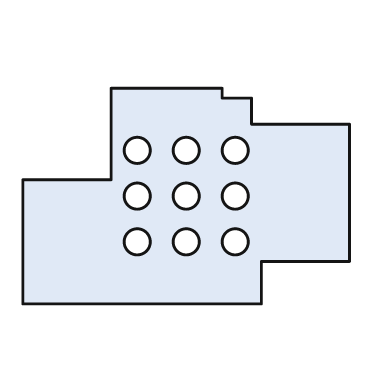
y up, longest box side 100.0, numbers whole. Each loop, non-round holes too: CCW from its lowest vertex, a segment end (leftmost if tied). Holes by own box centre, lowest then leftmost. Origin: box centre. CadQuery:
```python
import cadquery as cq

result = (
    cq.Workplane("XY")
    .moveTo(-50.0, -33.0)
    .lineTo(23.0, -33.0)
    .lineTo(23.0, -20.0)
    .lineTo(50.0, -20.0)
    .lineTo(50.0, 22.0)
    .lineTo(20.0, 22.0)
    .lineTo(20.0, 30.0)
    .lineTo(11.0, 30.0)
    .lineTo(11.0, 33.0)
    .lineTo(-23.0, 33.0)
    .lineTo(-23.0, 5.0)
    .lineTo(-50.0, 5.0)
    .close()
    .moveTo(-15.0, -14.0)
    .circle(4.0)
    .moveTo(0.0, -14.0)
    .circle(4.0)
    .moveTo(15.0, -14.0)
    .circle(4.0)
    .moveTo(-15.0, 0.0)
    .circle(4.0)
    .moveTo(0.0, 0.0)
    .circle(4.0)
    .moveTo(15.0, 0.0)
    .circle(4.0)
    .moveTo(-15.0, 14.0)
    .circle(4.0)
    .moveTo(0.0, 14.0)
    .circle(4.0)
    .moveTo(15.0, 14.0)
    .circle(4.0)
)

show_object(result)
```